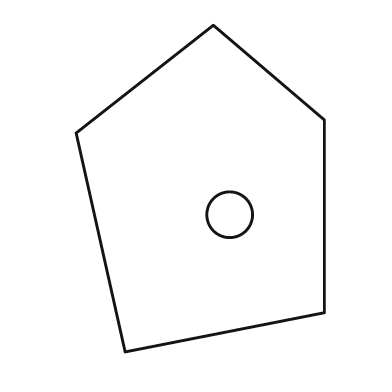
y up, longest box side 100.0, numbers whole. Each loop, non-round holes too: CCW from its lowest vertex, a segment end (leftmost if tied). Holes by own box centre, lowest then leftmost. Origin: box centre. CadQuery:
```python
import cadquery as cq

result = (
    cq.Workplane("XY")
    .moveTo(-23.0, -50.0)
    .lineTo(38.0, -38.0)
    .lineTo(38.0, 21.0)
    .lineTo(4.0, 50.0)
    .lineTo(-38.0, 17.0)
    .close()
    .moveTo(9.0, -8.0)
    .circle(7.0)
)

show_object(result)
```